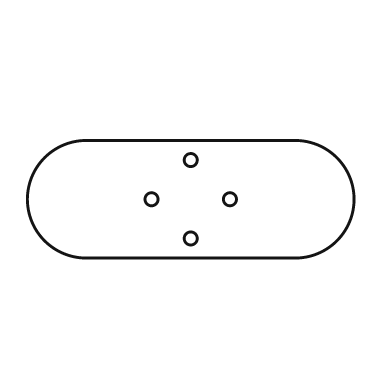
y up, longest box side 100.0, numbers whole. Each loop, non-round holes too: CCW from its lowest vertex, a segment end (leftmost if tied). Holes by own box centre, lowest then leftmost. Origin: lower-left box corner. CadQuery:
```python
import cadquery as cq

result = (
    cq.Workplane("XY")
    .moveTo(18.0, 0.0)
    .lineTo(82.0, 0.0)
    .threePointArc((100.0, 18.0), (82.0, 36.0))
    .lineTo(18.0, 36.0)
    .threePointArc((0.0, 18.0), (18.0, 0.0))
    .close()
    .moveTo(50.0, 6.0)
    .circle(2.0)
    .moveTo(38.0, 18.0)
    .circle(2.0)
    .moveTo(62.0, 18.0)
    .circle(2.0)
    .moveTo(50.0, 30.0)
    .circle(2.0)
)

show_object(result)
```